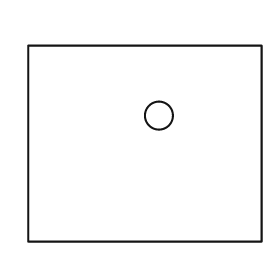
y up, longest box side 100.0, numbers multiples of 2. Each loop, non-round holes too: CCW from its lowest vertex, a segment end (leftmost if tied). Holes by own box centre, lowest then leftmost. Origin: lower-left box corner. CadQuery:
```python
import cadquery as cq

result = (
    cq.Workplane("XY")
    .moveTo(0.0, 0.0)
    .lineTo(100.0, 0.0)
    .lineTo(100.0, 84.0)
    .lineTo(0.0, 84.0)
    .close()
    .moveTo(56.0, 54.0)
    .circle(6.0)
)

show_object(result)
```